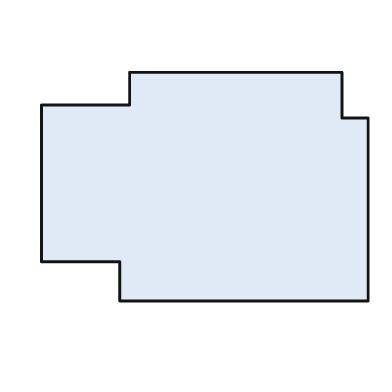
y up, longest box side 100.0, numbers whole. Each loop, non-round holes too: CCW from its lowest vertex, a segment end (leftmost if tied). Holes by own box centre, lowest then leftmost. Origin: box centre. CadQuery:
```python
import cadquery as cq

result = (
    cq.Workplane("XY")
    .moveTo(-26.0, -35.0)
    .lineTo(50.0, -35.0)
    .lineTo(50.0, 21.0)
    .lineTo(42.0, 21.0)
    .lineTo(42.0, 35.0)
    .lineTo(-23.0, 35.0)
    .lineTo(-23.0, 25.0)
    .lineTo(-50.0, 25.0)
    .lineTo(-50.0, -23.0)
    .lineTo(-26.0, -23.0)
    .close()
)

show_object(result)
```